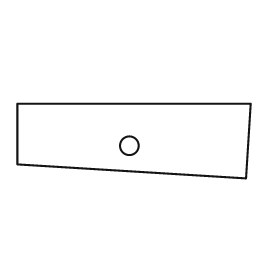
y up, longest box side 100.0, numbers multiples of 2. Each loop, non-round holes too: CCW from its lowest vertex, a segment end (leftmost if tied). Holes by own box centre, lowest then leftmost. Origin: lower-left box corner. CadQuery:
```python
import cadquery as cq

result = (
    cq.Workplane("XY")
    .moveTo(98.0, 0.0)
    .lineTo(100.0, 32.0)
    .lineTo(0.0, 32.0)
    .lineTo(0.0, 6.0)
    .close()
    .moveTo(48.0, 14.0)
    .circle(4.0)
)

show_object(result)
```